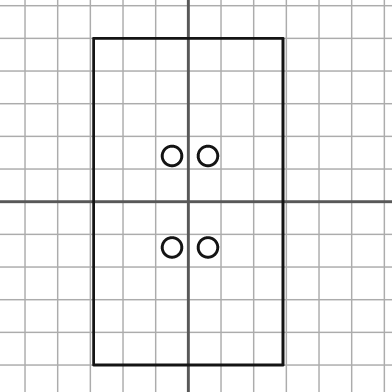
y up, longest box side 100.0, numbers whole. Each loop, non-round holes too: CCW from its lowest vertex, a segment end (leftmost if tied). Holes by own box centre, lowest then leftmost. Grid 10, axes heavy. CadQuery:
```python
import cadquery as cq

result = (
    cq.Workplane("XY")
    .moveTo(-29.0, -50.0)
    .lineTo(29.0, -50.0)
    .lineTo(29.0, 50.0)
    .lineTo(-29.0, 50.0)
    .close()
    .moveTo(-5.0, -14.0)
    .circle(3.0)
    .moveTo(6.0, -14.0)
    .circle(3.0)
    .moveTo(-5.0, 14.0)
    .circle(3.0)
    .moveTo(6.0, 14.0)
    .circle(3.0)
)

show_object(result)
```